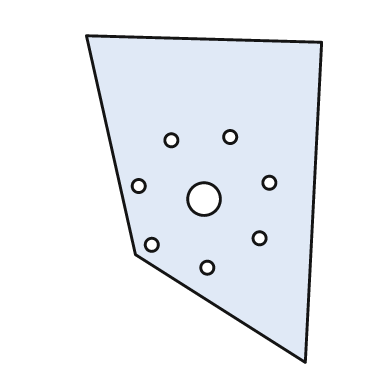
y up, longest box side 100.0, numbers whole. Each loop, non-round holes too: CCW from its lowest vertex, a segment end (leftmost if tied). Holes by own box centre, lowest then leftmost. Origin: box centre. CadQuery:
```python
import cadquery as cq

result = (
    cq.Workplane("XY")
    .moveTo(31.0, -50.0)
    .lineTo(36.0, 48.0)
    .lineTo(-36.0, 50.0)
    .lineTo(-21.0, -17.0)
    .close()
    .moveTo(1.0, -21.0)
    .circle(2.0)
    .moveTo(-16.0, -14.0)
    .circle(2.0)
    .moveTo(17.0, -12.0)
    .circle(2.0)
    .moveTo(0.0, 0.0)
    .circle(5.0)
    .moveTo(-20.0, 4.0)
    .circle(2.0)
    .moveTo(20.0, 5.0)
    .circle(2.0)
    .moveTo(-10.0, 18.0)
    .circle(2.0)
    .moveTo(8.0, 19.0)
    .circle(2.0)
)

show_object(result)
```